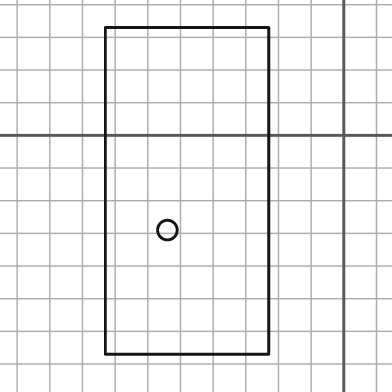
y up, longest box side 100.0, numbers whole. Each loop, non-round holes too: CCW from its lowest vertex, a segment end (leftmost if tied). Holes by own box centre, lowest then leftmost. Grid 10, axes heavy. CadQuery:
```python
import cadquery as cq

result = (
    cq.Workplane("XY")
    .moveTo(-73.0, -67.0)
    .lineTo(-23.0, -67.0)
    .lineTo(-23.0, 33.0)
    .lineTo(-73.0, 33.0)
    .close()
    .moveTo(-54.0, -29.0)
    .circle(3.0)
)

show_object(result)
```